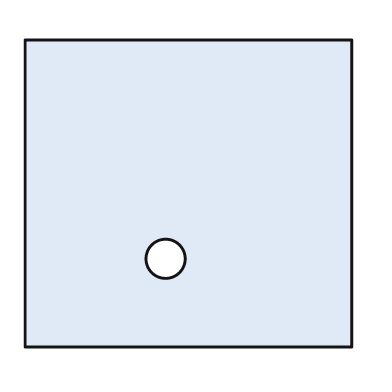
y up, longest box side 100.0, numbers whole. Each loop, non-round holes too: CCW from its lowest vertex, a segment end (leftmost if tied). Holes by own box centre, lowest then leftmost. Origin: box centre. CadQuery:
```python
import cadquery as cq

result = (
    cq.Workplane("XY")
    .moveTo(-50.0, -47.0)
    .lineTo(50.0, -47.0)
    .lineTo(50.0, 47.0)
    .lineTo(-50.0, 47.0)
    .close()
    .moveTo(-7.0, -20.0)
    .circle(6.0)
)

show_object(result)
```